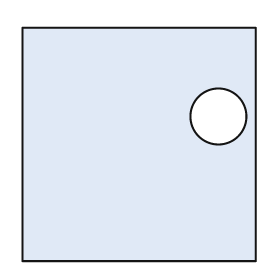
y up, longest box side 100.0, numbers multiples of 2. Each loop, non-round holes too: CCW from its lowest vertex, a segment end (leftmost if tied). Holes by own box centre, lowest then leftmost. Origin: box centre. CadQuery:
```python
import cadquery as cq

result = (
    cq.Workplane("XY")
    .moveTo(-50.0, -50.0)
    .lineTo(50.0, -50.0)
    .lineTo(50.0, 50.0)
    .lineTo(-50.0, 50.0)
    .close()
    .moveTo(34.0, 12.0)
    .circle(12.0)
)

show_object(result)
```